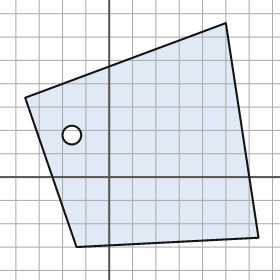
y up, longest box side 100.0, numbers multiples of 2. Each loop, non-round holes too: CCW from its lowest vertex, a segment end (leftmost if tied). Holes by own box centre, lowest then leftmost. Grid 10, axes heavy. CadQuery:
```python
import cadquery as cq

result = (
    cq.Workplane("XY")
    .moveTo(-14.0, -30.0)
    .lineTo(64.0, -26.0)
    .lineTo(50.0, 66.0)
    .lineTo(-36.0, 34.0)
    .close()
    .moveTo(-16.0, 18.0)
    .circle(4.0)
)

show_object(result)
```